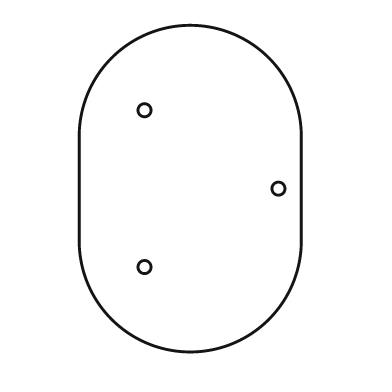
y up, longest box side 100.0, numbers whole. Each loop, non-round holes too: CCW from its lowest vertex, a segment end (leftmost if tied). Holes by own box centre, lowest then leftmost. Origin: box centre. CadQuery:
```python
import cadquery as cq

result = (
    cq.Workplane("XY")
    .moveTo(-34.0, -16.0)
    .threePointArc((0.0, -50.0), (34.0, -16.0))
    .lineTo(34.0, 16.0)
    .threePointArc((0.0, 50.0), (-34.0, 16.0))
    .close()
    .moveTo(-14.0, -24.0)
    .circle(2.0)
    .moveTo(27.0, 0.0)
    .circle(2.0)
    .moveTo(-14.0, 24.0)
    .circle(2.0)
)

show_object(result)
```